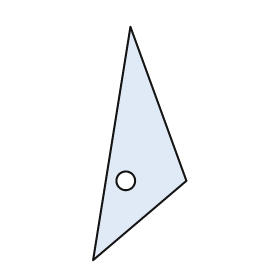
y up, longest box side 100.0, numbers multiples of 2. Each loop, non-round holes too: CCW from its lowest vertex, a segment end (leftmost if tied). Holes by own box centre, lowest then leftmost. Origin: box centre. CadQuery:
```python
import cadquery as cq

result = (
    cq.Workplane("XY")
    .moveTo(-20.0, -50.0)
    .lineTo(20.0, -16.0)
    .lineTo(-4.0, 50.0)
    .close()
    .moveTo(-6.0, -16.0)
    .circle(4.0)
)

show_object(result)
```